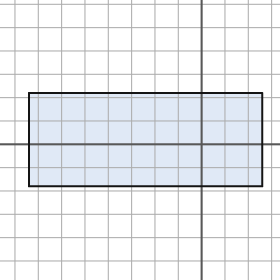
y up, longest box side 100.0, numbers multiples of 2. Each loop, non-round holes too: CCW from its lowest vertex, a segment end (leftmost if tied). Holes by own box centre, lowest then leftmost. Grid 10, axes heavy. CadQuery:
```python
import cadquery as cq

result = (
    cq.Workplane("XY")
    .moveTo(-74.0, -18.0)
    .lineTo(26.0, -18.0)
    .lineTo(26.0, 22.0)
    .lineTo(-74.0, 22.0)
    .close()
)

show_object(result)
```